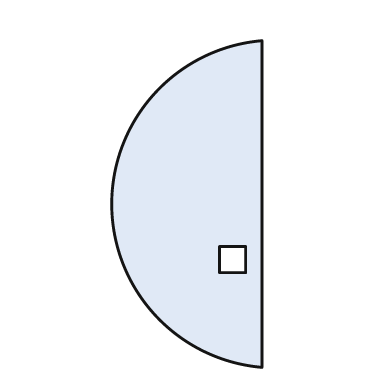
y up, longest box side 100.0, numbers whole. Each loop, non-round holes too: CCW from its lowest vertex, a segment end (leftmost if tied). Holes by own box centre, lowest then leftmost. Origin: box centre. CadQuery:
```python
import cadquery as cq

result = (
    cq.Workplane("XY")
    .moveTo(23.0, -50.0)
    .lineTo(23.0, 50.0)
    .threePointArc((-23.0, 0.0), (23.0, -50.0))
    .close()
    .moveTo(10.0, -21.0)
    .lineTo(18.0, -21.0)
    .lineTo(18.0, -13.0)
    .lineTo(10.0, -13.0)
    .close()
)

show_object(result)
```